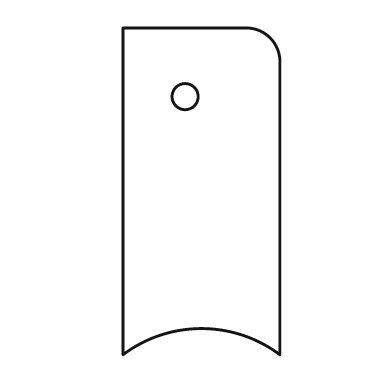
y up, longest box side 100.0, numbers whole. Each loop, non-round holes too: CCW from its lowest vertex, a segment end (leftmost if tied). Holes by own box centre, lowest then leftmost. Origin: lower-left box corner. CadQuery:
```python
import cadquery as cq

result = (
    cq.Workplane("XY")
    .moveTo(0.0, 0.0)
    .threePointArc((24.0, 8.0), (48.0, 0.0))
    .lineTo(48.0, 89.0)
    .threePointArc((45.0, 97.0), (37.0, 100.0))
    .lineTo(0.0, 100.0)
    .close()
    .moveTo(19.0, 79.0)
    .circle(4.0)
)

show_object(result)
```